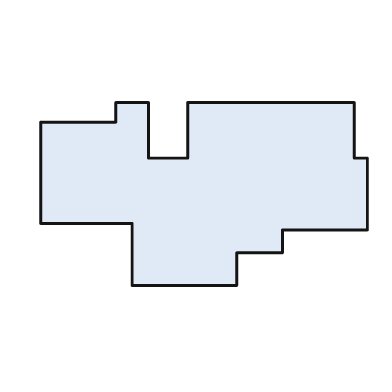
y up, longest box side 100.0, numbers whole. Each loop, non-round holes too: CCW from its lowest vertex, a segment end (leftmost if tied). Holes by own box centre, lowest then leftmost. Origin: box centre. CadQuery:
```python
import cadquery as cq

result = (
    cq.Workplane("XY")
    .moveTo(-22.0, -28.0)
    .lineTo(10.0, -28.0)
    .lineTo(10.0, -18.0)
    .lineTo(24.0, -18.0)
    .lineTo(24.0, -11.0)
    .lineTo(50.0, -11.0)
    .lineTo(50.0, 11.0)
    .lineTo(46.0, 11.0)
    .lineTo(46.0, 28.0)
    .lineTo(-5.0, 28.0)
    .lineTo(-5.0, 11.0)
    .lineTo(-17.0, 11.0)
    .lineTo(-17.0, 28.0)
    .lineTo(-27.0, 28.0)
    .lineTo(-27.0, 22.0)
    .lineTo(-50.0, 22.0)
    .lineTo(-50.0, -9.0)
    .lineTo(-22.0, -9.0)
    .close()
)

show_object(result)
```